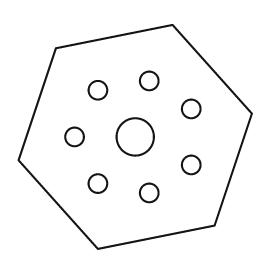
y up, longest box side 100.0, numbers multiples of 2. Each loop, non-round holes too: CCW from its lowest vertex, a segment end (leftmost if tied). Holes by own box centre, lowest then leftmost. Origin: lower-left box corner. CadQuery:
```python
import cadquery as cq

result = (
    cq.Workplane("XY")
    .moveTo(34.0, 0.0)
    .lineTo(84.0, 10.0)
    .lineTo(100.0, 58.0)
    .lineTo(66.0, 96.0)
    .lineTo(16.0, 86.0)
    .lineTo(0.0, 38.0)
    .close()
    .moveTo(56.0, 24.0)
    .circle(4.0)
    .moveTo(34.0, 28.0)
    .circle(4.0)
    .moveTo(74.0, 36.0)
    .circle(4.0)
    .moveTo(24.0, 48.0)
    .circle(4.0)
    .moveTo(50.0, 48.0)
    .circle(8.0)
    .moveTo(74.0, 60.0)
    .circle(4.0)
    .moveTo(34.0, 68.0)
    .circle(4.0)
    .moveTo(56.0, 72.0)
    .circle(4.0)
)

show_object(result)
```